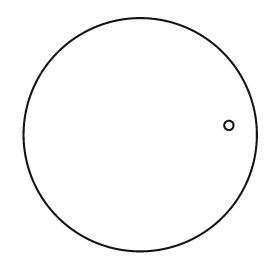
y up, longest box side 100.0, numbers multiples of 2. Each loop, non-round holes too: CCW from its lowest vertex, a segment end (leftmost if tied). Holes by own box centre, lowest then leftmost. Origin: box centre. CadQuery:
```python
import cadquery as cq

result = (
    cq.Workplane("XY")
    .moveTo(0.0, 0.0)
    .circle(50.0)
    .moveTo(38.0, 4.0)
    .circle(2.0)
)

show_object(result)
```